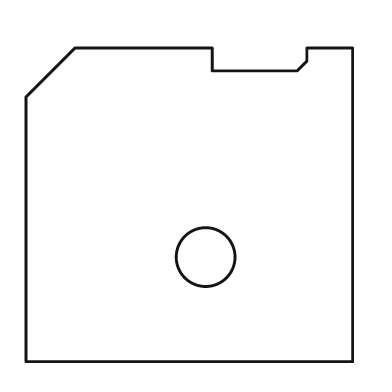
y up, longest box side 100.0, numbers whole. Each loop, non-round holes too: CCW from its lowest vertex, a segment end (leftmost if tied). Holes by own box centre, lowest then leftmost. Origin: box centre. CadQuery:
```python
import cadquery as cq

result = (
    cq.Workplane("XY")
    .moveTo(-50.0, -48.0)
    .lineTo(50.0, -48.0)
    .lineTo(50.0, 48.0)
    .lineTo(36.0, 48.0)
    .lineTo(36.0, 44.0)
    .lineTo(33.0, 41.0)
    .lineTo(7.0, 41.0)
    .lineTo(7.0, 48.0)
    .lineTo(-35.0, 48.0)
    .lineTo(-50.0, 33.0)
    .close()
    .moveTo(5.0, -16.0)
    .circle(9.0)
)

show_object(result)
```